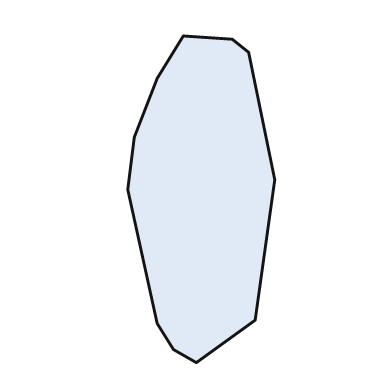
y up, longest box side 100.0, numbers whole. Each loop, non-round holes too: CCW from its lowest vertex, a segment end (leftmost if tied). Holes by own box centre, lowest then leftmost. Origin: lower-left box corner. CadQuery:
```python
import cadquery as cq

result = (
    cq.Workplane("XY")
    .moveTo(21.0, 0.0)
    .lineTo(39.0, 13.0)
    .lineTo(45.0, 56.0)
    .lineTo(37.0, 95.0)
    .lineTo(32.0, 99.0)
    .lineTo(17.0, 100.0)
    .lineTo(9.0, 87.0)
    .lineTo(2.0, 69.0)
    .lineTo(0.0, 53.0)
    .lineTo(9.0, 12.0)
    .lineTo(14.0, 4.0)
    .close()
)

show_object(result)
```